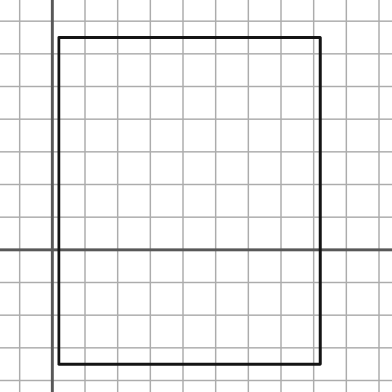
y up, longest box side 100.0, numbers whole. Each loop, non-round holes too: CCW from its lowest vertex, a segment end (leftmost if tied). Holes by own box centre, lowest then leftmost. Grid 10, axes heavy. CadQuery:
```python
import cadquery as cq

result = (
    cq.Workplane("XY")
    .moveTo(2.0, -35.0)
    .lineTo(82.0, -35.0)
    .lineTo(82.0, 65.0)
    .lineTo(2.0, 65.0)
    .close()
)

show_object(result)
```